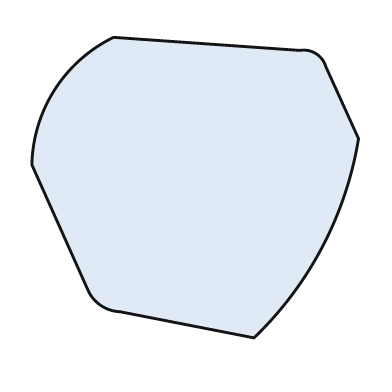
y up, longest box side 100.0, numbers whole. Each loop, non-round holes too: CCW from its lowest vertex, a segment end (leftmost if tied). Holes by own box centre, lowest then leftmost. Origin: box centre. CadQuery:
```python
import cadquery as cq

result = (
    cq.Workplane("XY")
    .moveTo(18.0, -46.0)
    .threePointArc((39.0, -18.0), (50.0, 15.0))
    .lineTo(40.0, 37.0)
    .threePointArc((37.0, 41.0), (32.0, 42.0))
    .lineTo(-25.0, 46.0)
    .threePointArc((-43.0, 30.0), (-50.0, 7.0))
    .lineTo(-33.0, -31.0)
    .threePointArc((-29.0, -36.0), (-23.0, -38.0))
    .close()
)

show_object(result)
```